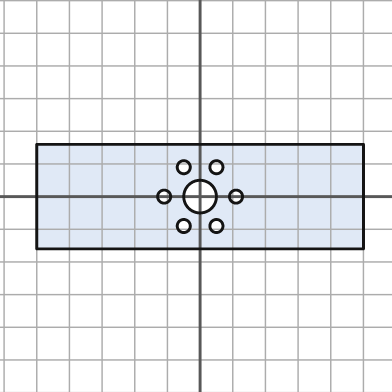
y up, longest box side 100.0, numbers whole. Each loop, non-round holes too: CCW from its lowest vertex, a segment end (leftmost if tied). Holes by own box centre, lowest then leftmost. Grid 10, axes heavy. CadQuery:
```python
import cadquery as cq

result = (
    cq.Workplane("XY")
    .moveTo(-50.0, -16.0)
    .lineTo(50.0, -16.0)
    .lineTo(50.0, 16.0)
    .lineTo(-50.0, 16.0)
    .close()
    .moveTo(-5.0, -9.0)
    .circle(2.0)
    .moveTo(5.0, -9.0)
    .circle(2.0)
    .moveTo(-11.0, 0.0)
    .circle(2.0)
    .moveTo(0.0, 0.0)
    .circle(5.0)
    .moveTo(11.0, 0.0)
    .circle(2.0)
    .moveTo(-5.0, 9.0)
    .circle(2.0)
    .moveTo(5.0, 9.0)
    .circle(2.0)
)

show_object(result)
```